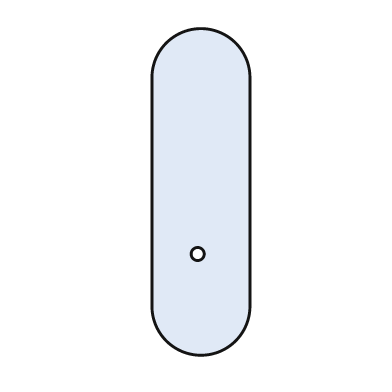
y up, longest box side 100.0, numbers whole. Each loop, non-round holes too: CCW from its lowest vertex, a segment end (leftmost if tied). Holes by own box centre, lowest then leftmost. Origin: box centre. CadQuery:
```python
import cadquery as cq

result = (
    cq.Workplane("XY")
    .moveTo(-15.0, -35.0)
    .threePointArc((0.0, -50.0), (15.0, -35.0))
    .lineTo(15.0, 35.0)
    .threePointArc((0.0, 50.0), (-15.0, 35.0))
    .close()
    .moveTo(-1.0, -19.0)
    .circle(2.0)
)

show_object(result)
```